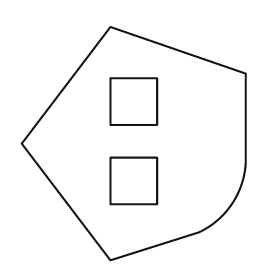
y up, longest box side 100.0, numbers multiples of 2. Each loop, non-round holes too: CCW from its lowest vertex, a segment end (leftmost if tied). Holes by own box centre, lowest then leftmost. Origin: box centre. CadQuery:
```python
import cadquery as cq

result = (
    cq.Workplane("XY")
    .moveTo(-10.0, -50.0)
    .lineTo(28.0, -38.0)
    .threePointArc((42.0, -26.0), (48.0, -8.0))
    .lineTo(48.0, 30.0)
    .lineTo(-10.0, 50.0)
    .lineTo(-48.0, 0.0)
    .close()
    .moveTo(-10.0, -26.0)
    .lineTo(10.0, -26.0)
    .lineTo(10.0, -6.0)
    .lineTo(-10.0, -6.0)
    .close()
    .moveTo(-10.0, 8.0)
    .lineTo(10.0, 8.0)
    .lineTo(10.0, 28.0)
    .lineTo(-10.0, 28.0)
    .close()
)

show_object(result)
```